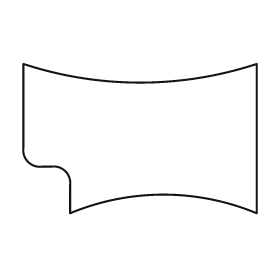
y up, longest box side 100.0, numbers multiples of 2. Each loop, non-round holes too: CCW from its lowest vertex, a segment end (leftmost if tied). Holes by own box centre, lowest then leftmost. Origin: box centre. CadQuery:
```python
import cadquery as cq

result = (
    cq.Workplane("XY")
    .moveTo(-30.0, -32.0)
    .threePointArc((10.0, -24.0), (50.0, -32.0))
    .lineTo(50.0, 32.0)
    .threePointArc((0.0, 24.0), (-50.0, 32.0))
    .lineTo(-50.0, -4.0)
    .threePointArc((-48.0, -10.0), (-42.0, -12.0))
    .lineTo(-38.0, -12.0)
    .threePointArc((-32.0, -14.0), (-30.0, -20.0))
    .close()
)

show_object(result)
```